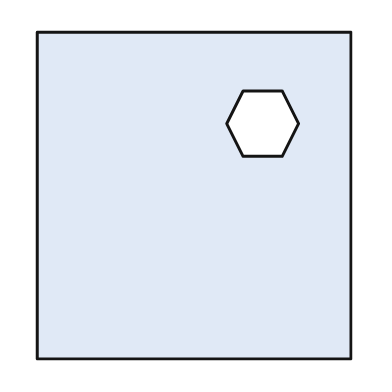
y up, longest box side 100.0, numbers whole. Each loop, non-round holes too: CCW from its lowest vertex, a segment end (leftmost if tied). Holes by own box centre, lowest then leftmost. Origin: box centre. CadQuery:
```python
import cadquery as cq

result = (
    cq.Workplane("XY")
    .moveTo(-48.0, -50.0)
    .lineTo(48.0, -50.0)
    .lineTo(48.0, 50.0)
    .lineTo(-48.0, 50.0)
    .close()
    .moveTo(15.0, 12.0)
    .lineTo(27.0, 12.0)
    .lineTo(32.0, 22.0)
    .lineTo(27.0, 32.0)
    .lineTo(15.0, 32.0)
    .lineTo(10.0, 22.0)
    .close()
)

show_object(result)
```